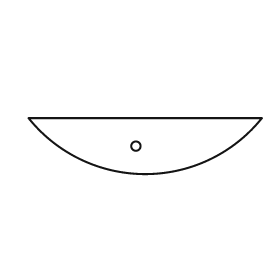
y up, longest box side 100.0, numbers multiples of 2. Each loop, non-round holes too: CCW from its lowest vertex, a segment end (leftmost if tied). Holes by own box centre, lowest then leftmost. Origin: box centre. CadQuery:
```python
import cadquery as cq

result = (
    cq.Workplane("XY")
    .moveTo(-50.0, 12.0)
    .threePointArc((0.0, -12.0), (50.0, 12.0))
    .close()
    .moveTo(-4.0, 0.0)
    .circle(2.0)
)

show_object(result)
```